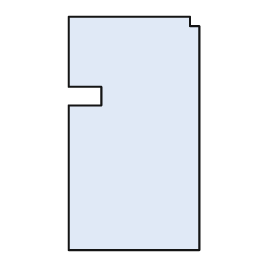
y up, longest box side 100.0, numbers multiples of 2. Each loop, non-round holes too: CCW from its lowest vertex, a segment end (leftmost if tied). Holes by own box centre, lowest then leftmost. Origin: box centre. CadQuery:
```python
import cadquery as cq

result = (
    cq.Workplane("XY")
    .moveTo(-28.0, -50.0)
    .lineTo(28.0, -50.0)
    .lineTo(28.0, 46.0)
    .lineTo(24.0, 46.0)
    .lineTo(24.0, 50.0)
    .lineTo(-28.0, 50.0)
    .lineTo(-28.0, 20.0)
    .lineTo(-14.0, 20.0)
    .lineTo(-14.0, 12.0)
    .lineTo(-28.0, 12.0)
    .close()
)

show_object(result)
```